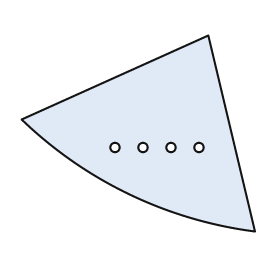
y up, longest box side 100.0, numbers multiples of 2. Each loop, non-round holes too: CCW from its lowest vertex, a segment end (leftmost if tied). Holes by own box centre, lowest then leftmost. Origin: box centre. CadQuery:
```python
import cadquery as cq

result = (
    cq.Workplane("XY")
    .moveTo(50.0, -42.0)
    .lineTo(30.0, 42.0)
    .lineTo(-50.0, 6.0)
    .threePointArc((-4.0, -26.0), (50.0, -42.0))
    .close()
    .moveTo(-10.0, -6.0)
    .circle(2.0)
    .moveTo(2.0, -6.0)
    .circle(2.0)
    .moveTo(14.0, -6.0)
    .circle(2.0)
    .moveTo(26.0, -6.0)
    .circle(2.0)
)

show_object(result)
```